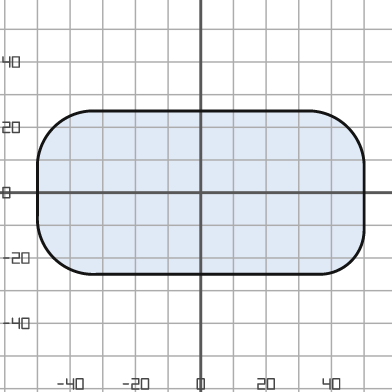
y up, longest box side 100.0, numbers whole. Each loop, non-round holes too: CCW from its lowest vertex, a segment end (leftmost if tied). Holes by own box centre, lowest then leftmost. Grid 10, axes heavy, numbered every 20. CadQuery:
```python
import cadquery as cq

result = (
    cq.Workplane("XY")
    .moveTo(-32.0, -25.0)
    .lineTo(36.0, -25.0)
    .threePointArc((46.0, -21.0), (50.0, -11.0))
    .lineTo(50.0, 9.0)
    .threePointArc((45.0, 20.0), (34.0, 25.0))
    .lineTo(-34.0, 25.0)
    .threePointArc((-45.0, 20.0), (-50.0, 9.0))
    .lineTo(-50.0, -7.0)
    .threePointArc((-45.0, -20.0), (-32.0, -25.0))
    .close()
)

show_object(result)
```